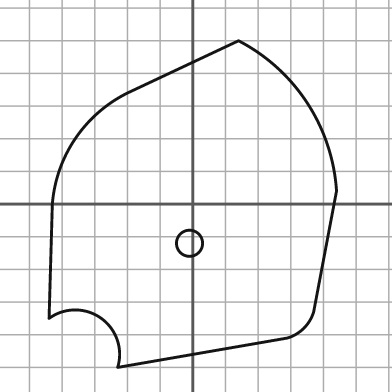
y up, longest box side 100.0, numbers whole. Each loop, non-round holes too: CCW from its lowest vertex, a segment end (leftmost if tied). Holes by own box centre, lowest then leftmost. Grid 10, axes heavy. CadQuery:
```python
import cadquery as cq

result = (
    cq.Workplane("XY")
    .moveTo(-23.0, -50.0)
    .lineTo(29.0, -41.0)
    .threePointArc((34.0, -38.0), (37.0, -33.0))
    .lineTo(44.0, 4.0)
    .threePointArc((35.0, 31.0), (14.0, 50.0))
    .lineTo(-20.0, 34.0)
    .threePointArc((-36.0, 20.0), (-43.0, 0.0))
    .lineTo(-44.0, -35.0)
    .threePointArc((-28.0, -35.0), (-23.0, -50.0))
    .close()
    .moveTo(-1.0, -12.0)
    .circle(4.0)
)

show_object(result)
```